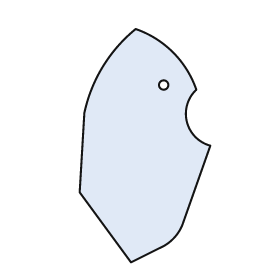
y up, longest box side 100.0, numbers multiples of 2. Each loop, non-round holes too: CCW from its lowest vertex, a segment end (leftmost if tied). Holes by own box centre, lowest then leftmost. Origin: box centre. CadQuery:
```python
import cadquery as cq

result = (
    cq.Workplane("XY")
    .moveTo(-6.0, -50.0)
    .lineTo(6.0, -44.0)
    .threePointArc((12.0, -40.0), (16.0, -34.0))
    .lineTo(28.0, 0.0)
    .threePointArc((18.0, 10.0), (22.0, 24.0))
    .threePointArc((12.0, 40.0), (-4.0, 50.0))
    .threePointArc((-18.0, 34.0), (-26.0, 14.0))
    .lineTo(-28.0, -20.0)
    .close()
    .moveTo(8.0, 26.0)
    .circle(2.0)
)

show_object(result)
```